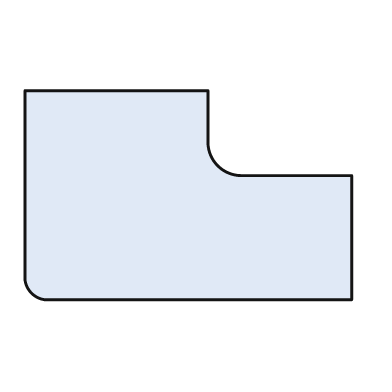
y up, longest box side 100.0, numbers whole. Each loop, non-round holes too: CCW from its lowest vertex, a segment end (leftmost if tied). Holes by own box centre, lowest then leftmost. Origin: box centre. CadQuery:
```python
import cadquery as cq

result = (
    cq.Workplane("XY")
    .moveTo(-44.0, -32.0)
    .lineTo(50.0, -32.0)
    .lineTo(50.0, 6.0)
    .lineTo(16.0, 6.0)
    .threePointArc((9.0, 9.0), (6.0, 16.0))
    .lineTo(6.0, 32.0)
    .lineTo(-50.0, 32.0)
    .lineTo(-50.0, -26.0)
    .threePointArc((-48.0, -30.0), (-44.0, -32.0))
    .close()
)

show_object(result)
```